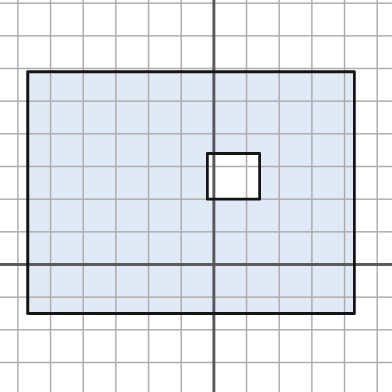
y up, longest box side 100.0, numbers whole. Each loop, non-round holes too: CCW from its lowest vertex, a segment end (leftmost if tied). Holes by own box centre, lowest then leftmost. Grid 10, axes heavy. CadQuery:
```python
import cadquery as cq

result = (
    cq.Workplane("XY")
    .moveTo(-57.0, -15.0)
    .lineTo(43.0, -15.0)
    .lineTo(43.0, 59.0)
    .lineTo(-57.0, 59.0)
    .close()
    .moveTo(-2.0, 20.0)
    .lineTo(14.0, 20.0)
    .lineTo(14.0, 34.0)
    .lineTo(-2.0, 34.0)
    .close()
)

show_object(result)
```